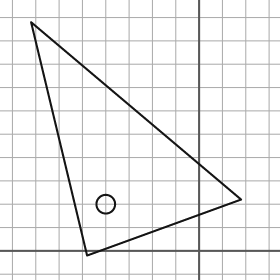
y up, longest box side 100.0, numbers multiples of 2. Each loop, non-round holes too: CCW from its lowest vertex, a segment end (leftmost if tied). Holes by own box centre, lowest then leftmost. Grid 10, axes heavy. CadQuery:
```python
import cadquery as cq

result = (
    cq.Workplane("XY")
    .moveTo(-48.0, -2.0)
    .lineTo(18.0, 22.0)
    .lineTo(-72.0, 98.0)
    .close()
    .moveTo(-40.0, 20.0)
    .circle(4.0)
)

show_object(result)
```